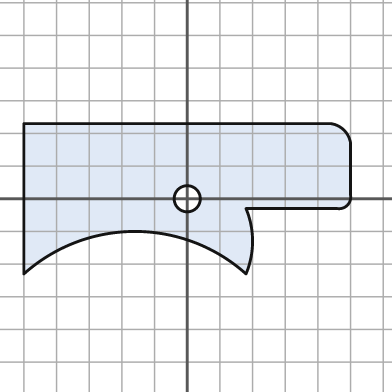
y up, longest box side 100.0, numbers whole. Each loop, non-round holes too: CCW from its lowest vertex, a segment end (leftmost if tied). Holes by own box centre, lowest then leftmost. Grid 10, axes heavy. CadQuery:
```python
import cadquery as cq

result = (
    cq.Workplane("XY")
    .moveTo(-50.0, -23.0)
    .threePointArc((-16.0, -10.0), (18.0, -23.0))
    .threePointArc((20.0, -13.0), (18.0, -3.0))
    .lineTo(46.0, -3.0)
    .threePointArc((49.0, -2.0), (50.0, 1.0))
    .lineTo(50.0, 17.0)
    .threePointArc((48.0, 21.0), (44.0, 23.0))
    .lineTo(-50.0, 23.0)
    .close()
    .moveTo(0.0, 0.0)
    .circle(4.0)
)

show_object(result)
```